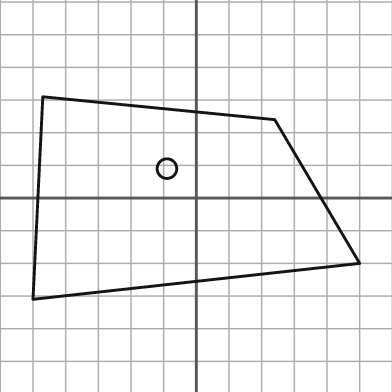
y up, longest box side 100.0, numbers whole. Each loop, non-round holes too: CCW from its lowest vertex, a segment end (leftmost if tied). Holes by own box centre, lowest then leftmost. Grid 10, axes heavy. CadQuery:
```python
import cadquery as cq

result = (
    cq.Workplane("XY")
    .moveTo(-50.0, -31.0)
    .lineTo(50.0, -20.0)
    .lineTo(24.0, 24.0)
    .lineTo(-47.0, 31.0)
    .close()
    .moveTo(-9.0, 9.0)
    .circle(3.0)
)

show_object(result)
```